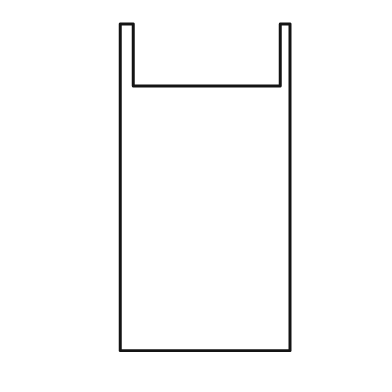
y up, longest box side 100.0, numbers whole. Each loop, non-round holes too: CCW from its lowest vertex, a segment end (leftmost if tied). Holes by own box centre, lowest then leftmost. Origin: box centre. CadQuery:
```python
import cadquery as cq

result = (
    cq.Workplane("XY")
    .moveTo(-26.0, -50.0)
    .lineTo(26.0, -50.0)
    .lineTo(26.0, 50.0)
    .lineTo(23.0, 50.0)
    .lineTo(23.0, 31.0)
    .lineTo(-22.0, 31.0)
    .lineTo(-22.0, 50.0)
    .lineTo(-26.0, 50.0)
    .close()
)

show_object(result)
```